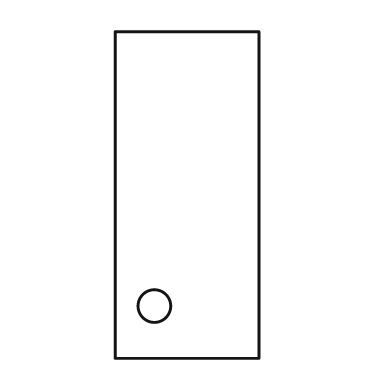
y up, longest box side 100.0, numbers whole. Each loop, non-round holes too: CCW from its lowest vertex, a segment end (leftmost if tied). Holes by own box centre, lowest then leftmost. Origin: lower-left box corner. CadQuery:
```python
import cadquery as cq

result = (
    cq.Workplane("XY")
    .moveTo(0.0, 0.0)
    .lineTo(44.0, 0.0)
    .lineTo(44.0, 100.0)
    .lineTo(0.0, 100.0)
    .close()
    .moveTo(12.0, 16.0)
    .circle(5.0)
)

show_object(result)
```